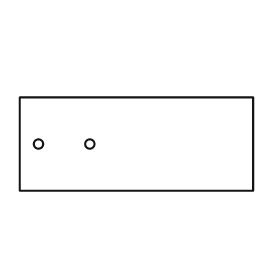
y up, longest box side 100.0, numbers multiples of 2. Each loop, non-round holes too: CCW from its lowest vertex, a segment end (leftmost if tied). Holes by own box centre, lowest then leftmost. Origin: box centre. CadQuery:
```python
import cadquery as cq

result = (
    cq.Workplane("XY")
    .moveTo(-50.0, -20.0)
    .lineTo(50.0, -20.0)
    .lineTo(50.0, 20.0)
    .lineTo(-50.0, 20.0)
    .close()
    .moveTo(-42.0, 0.0)
    .circle(2.0)
    .moveTo(-20.0, 0.0)
    .circle(2.0)
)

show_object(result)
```